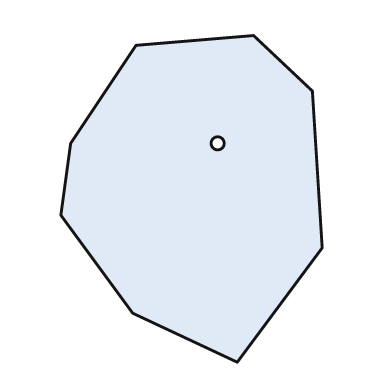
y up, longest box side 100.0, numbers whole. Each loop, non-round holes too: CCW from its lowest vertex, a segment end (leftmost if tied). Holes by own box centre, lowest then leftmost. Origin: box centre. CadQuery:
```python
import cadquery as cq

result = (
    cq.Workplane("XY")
    .moveTo(14.0, -50.0)
    .lineTo(40.0, -15.0)
    .lineTo(37.0, 33.0)
    .lineTo(19.0, 50.0)
    .lineTo(-17.0, 47.0)
    .lineTo(-37.0, 17.0)
    .lineTo(-40.0, -5.0)
    .lineTo(-18.0, -35.0)
    .close()
    .moveTo(8.0, 17.0)
    .circle(2.0)
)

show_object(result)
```